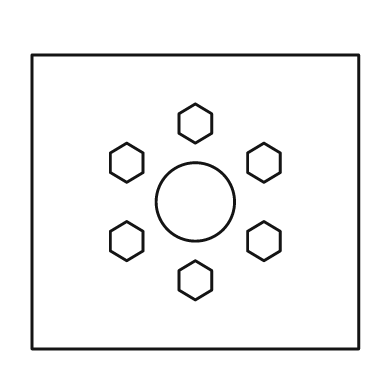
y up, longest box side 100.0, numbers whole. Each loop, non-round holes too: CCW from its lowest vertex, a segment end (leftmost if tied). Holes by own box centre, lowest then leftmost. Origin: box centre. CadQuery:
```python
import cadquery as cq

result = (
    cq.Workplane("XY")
    .moveTo(-50.0, -45.0)
    .lineTo(50.0, -45.0)
    .lineTo(50.0, 45.0)
    .lineTo(-50.0, 45.0)
    .close()
    .moveTo(0.0, -30.0)
    .lineTo(5.0, -27.0)
    .lineTo(5.0, -21.0)
    .lineTo(0.0, -18.0)
    .lineTo(-5.0, -21.0)
    .lineTo(-5.0, -27.0)
    .close()
    .moveTo(-21.0, -18.0)
    .lineTo(-16.0, -15.0)
    .lineTo(-16.0, -9.0)
    .lineTo(-21.0, -6.0)
    .lineTo(-26.0, -9.0)
    .lineTo(-26.0, -15.0)
    .close()
    .moveTo(21.0, -18.0)
    .lineTo(26.0, -15.0)
    .lineTo(26.0, -9.0)
    .lineTo(21.0, -6.0)
    .lineTo(16.0, -9.0)
    .lineTo(16.0, -15.0)
    .close()
    .moveTo(0.0, 0.0)
    .circle(12.0)
    .moveTo(-21.0, 6.0)
    .lineTo(-16.0, 9.0)
    .lineTo(-16.0, 15.0)
    .lineTo(-21.0, 18.0)
    .lineTo(-26.0, 15.0)
    .lineTo(-26.0, 9.0)
    .close()
    .moveTo(21.0, 6.0)
    .lineTo(26.0, 9.0)
    .lineTo(26.0, 15.0)
    .lineTo(21.0, 18.0)
    .lineTo(16.0, 15.0)
    .lineTo(16.0, 9.0)
    .close()
    .moveTo(0.0, 18.0)
    .lineTo(5.0, 21.0)
    .lineTo(5.0, 27.0)
    .lineTo(0.0, 30.0)
    .lineTo(-5.0, 27.0)
    .lineTo(-5.0, 21.0)
    .close()
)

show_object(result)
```